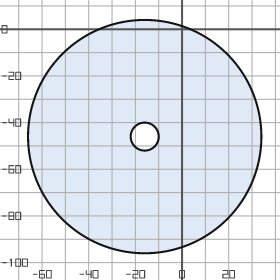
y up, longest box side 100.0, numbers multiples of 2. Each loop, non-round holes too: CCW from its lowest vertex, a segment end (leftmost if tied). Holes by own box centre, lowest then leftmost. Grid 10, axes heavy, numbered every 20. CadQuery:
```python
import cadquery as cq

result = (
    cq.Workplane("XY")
    .moveTo(-16.0, -46.0)
    .circle(50.0)
    .moveTo(-16.0, -46.0)
    .circle(6.0)
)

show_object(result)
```